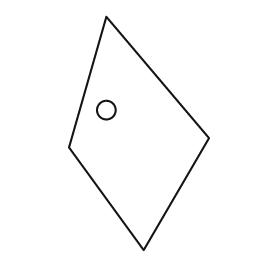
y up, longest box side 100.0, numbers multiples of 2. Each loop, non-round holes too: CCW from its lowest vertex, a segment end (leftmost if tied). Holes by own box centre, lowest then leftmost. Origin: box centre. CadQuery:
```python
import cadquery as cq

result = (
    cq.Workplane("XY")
    .moveTo(2.0, -50.0)
    .lineTo(30.0, -2.0)
    .lineTo(-14.0, 50.0)
    .lineTo(-30.0, -6.0)
    .close()
    .moveTo(-14.0, 10.0)
    .circle(4.0)
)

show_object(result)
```